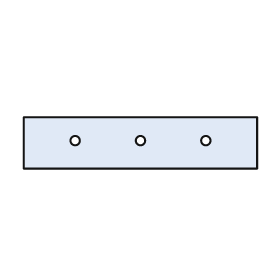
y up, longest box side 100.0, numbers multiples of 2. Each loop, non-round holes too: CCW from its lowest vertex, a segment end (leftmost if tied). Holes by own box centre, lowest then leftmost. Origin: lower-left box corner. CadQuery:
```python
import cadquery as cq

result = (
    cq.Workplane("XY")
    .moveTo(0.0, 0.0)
    .lineTo(100.0, 0.0)
    .lineTo(100.0, 22.0)
    .lineTo(0.0, 22.0)
    .close()
    .moveTo(22.0, 12.0)
    .circle(2.0)
    .moveTo(50.0, 12.0)
    .circle(2.0)
    .moveTo(78.0, 12.0)
    .circle(2.0)
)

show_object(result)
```